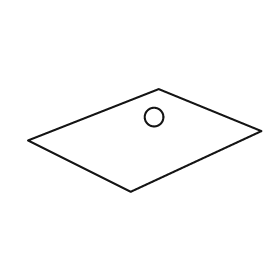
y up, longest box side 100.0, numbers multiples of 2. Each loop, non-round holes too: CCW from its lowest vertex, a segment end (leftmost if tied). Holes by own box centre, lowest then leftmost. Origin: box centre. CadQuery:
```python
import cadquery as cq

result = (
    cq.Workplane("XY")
    .moveTo(-6.0, -22.0)
    .lineTo(50.0, 4.0)
    .lineTo(6.0, 22.0)
    .lineTo(-50.0, 0.0)
    .close()
    .moveTo(4.0, 10.0)
    .circle(4.0)
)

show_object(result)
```